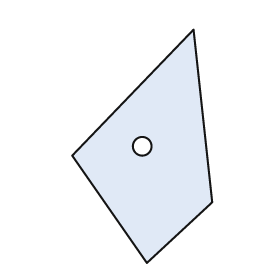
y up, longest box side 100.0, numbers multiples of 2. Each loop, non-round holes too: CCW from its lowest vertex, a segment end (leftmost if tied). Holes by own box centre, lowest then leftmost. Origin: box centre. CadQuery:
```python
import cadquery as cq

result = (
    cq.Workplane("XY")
    .moveTo(2.0, -50.0)
    .lineTo(30.0, -24.0)
    .lineTo(22.0, 50.0)
    .lineTo(-30.0, -4.0)
    .close()
    .moveTo(0.0, 0.0)
    .circle(4.0)
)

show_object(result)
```